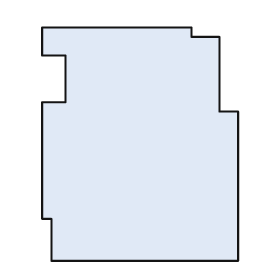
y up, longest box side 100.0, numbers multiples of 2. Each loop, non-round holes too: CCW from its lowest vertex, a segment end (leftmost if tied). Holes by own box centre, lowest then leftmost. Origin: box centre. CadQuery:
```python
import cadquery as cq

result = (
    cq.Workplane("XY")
    .moveTo(-38.0, -50.0)
    .lineTo(42.0, -50.0)
    .lineTo(42.0, 14.0)
    .lineTo(34.0, 14.0)
    .lineTo(34.0, 46.0)
    .lineTo(22.0, 46.0)
    .lineTo(22.0, 50.0)
    .lineTo(-42.0, 50.0)
    .lineTo(-42.0, 38.0)
    .lineTo(-32.0, 38.0)
    .lineTo(-32.0, 18.0)
    .lineTo(-42.0, 18.0)
    .lineTo(-42.0, -32.0)
    .lineTo(-38.0, -32.0)
    .close()
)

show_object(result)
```